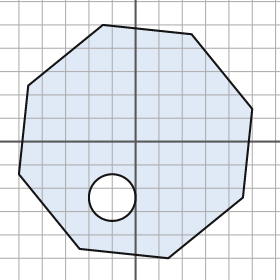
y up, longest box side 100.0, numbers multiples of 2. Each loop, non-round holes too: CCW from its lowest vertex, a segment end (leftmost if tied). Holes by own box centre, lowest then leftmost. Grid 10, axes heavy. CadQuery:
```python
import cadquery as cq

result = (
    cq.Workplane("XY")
    .moveTo(14.0, -50.0)
    .lineTo(46.0, -24.0)
    .lineTo(50.0, 14.0)
    .lineTo(24.0, 46.0)
    .lineTo(-14.0, 50.0)
    .lineTo(-46.0, 24.0)
    .lineTo(-50.0, -14.0)
    .lineTo(-24.0, -46.0)
    .close()
    .moveTo(-10.0, -24.0)
    .circle(10.0)
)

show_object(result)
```